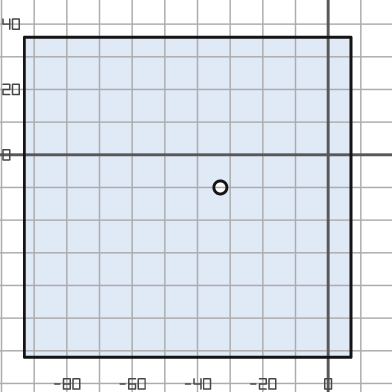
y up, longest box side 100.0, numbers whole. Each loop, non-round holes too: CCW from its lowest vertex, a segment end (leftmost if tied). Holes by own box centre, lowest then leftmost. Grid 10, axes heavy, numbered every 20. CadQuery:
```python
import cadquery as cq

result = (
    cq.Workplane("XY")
    .moveTo(-93.0, -62.0)
    .lineTo(7.0, -62.0)
    .lineTo(7.0, 36.0)
    .lineTo(-93.0, 36.0)
    .close()
    .moveTo(-33.0, -10.0)
    .circle(2.0)
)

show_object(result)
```